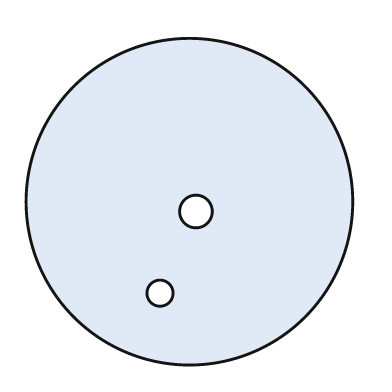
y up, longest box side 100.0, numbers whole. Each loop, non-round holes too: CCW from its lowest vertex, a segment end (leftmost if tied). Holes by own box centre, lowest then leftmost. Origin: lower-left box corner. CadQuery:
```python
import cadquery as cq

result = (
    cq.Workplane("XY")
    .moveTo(50.0, 50.0)
    .circle(50.0)
    .moveTo(41.0, 22.0)
    .circle(4.0)
    .moveTo(52.0, 47.0)
    .circle(5.0)
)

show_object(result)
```